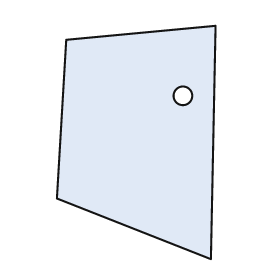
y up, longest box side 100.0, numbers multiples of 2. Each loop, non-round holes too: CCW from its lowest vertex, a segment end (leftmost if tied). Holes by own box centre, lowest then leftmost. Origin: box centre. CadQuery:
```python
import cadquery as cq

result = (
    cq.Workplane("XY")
    .moveTo(32.0, -50.0)
    .lineTo(34.0, 50.0)
    .lineTo(-30.0, 44.0)
    .lineTo(-34.0, -24.0)
    .close()
    .moveTo(20.0, 20.0)
    .circle(4.0)
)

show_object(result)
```